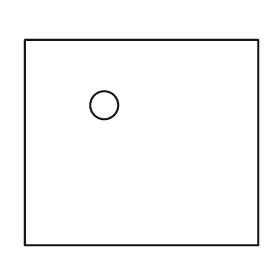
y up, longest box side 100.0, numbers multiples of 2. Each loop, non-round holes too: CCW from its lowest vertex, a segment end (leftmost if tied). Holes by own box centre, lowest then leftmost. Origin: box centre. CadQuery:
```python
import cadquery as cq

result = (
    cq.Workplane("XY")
    .moveTo(-50.0, -44.0)
    .lineTo(50.0, -44.0)
    .lineTo(50.0, 44.0)
    .lineTo(-50.0, 44.0)
    .close()
    .moveTo(-16.0, 16.0)
    .circle(6.0)
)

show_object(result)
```